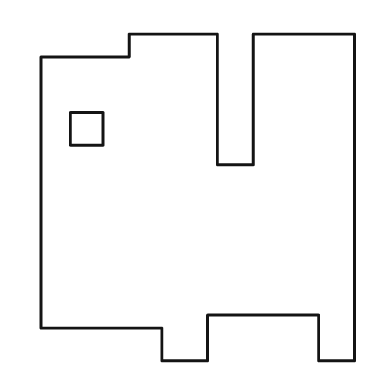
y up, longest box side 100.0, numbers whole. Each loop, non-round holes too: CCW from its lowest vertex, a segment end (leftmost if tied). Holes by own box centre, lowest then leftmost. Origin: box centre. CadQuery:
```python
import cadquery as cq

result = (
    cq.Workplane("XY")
    .moveTo(-11.0, -50.0)
    .lineTo(3.0, -50.0)
    .lineTo(3.0, -36.0)
    .lineTo(37.0, -36.0)
    .lineTo(37.0, -50.0)
    .lineTo(48.0, -50.0)
    .lineTo(48.0, 50.0)
    .lineTo(17.0, 50.0)
    .lineTo(17.0, 10.0)
    .lineTo(6.0, 10.0)
    .lineTo(6.0, 50.0)
    .lineTo(-21.0, 50.0)
    .lineTo(-21.0, 43.0)
    .lineTo(-48.0, 43.0)
    .lineTo(-48.0, -40.0)
    .lineTo(-11.0, -40.0)
    .close()
    .moveTo(-39.0, 16.0)
    .lineTo(-29.0, 16.0)
    .lineTo(-29.0, 26.0)
    .lineTo(-39.0, 26.0)
    .close()
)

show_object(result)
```